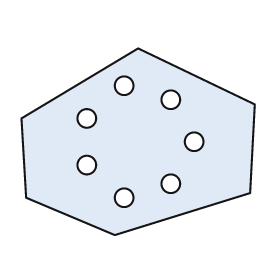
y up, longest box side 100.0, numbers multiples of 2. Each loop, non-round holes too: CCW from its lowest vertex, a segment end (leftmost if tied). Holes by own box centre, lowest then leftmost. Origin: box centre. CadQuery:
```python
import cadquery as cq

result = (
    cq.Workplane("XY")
    .moveTo(-10.0, -40.0)
    .lineTo(48.0, -22.0)
    .lineTo(50.0, 16.0)
    .lineTo(0.0, 40.0)
    .lineTo(-50.0, 10.0)
    .lineTo(-48.0, -24.0)
    .close()
    .moveTo(-6.0, -24.0)
    .circle(4.0)
    .moveTo(14.0, -18.0)
    .circle(4.0)
    .moveTo(-22.0, -10.0)
    .circle(4.0)
    .moveTo(24.0, 0.0)
    .circle(4.0)
    .moveTo(-22.0, 10.0)
    .circle(4.0)
    .moveTo(14.0, 18.0)
    .circle(4.0)
    .moveTo(-6.0, 24.0)
    .circle(4.0)
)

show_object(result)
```